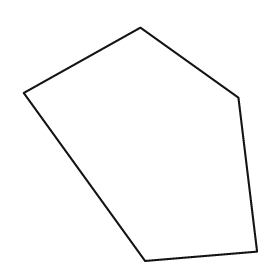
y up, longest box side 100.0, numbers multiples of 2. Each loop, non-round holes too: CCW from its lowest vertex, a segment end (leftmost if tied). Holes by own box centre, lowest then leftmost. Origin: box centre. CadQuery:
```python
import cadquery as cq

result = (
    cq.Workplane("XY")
    .moveTo(2.0, -50.0)
    .lineTo(50.0, -46.0)
    .lineTo(42.0, 20.0)
    .lineTo(0.0, 50.0)
    .lineTo(-50.0, 22.0)
    .close()
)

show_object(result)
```